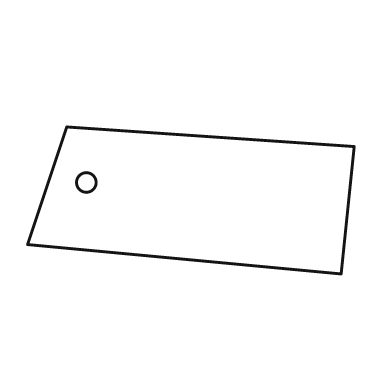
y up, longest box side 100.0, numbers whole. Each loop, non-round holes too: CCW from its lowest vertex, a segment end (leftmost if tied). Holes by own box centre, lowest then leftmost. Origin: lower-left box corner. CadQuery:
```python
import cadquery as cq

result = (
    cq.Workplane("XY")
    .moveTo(96.0, 0.0)
    .lineTo(100.0, 39.0)
    .lineTo(12.0, 45.0)
    .lineTo(0.0, 9.0)
    .close()
    .moveTo(18.0, 28.0)
    .circle(3.0)
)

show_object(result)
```